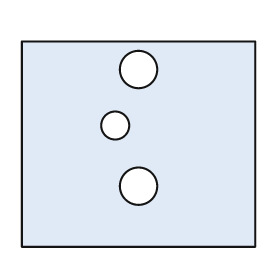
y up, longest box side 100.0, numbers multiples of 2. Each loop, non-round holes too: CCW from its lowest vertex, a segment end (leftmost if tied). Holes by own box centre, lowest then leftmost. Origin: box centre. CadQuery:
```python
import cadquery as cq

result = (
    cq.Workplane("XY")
    .moveTo(-50.0, -44.0)
    .lineTo(50.0, -44.0)
    .lineTo(50.0, 44.0)
    .lineTo(-50.0, 44.0)
    .close()
    .moveTo(0.0, -18.0)
    .circle(8.0)
    .moveTo(-10.0, 8.0)
    .circle(6.0)
    .moveTo(0.0, 32.0)
    .circle(8.0)
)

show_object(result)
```